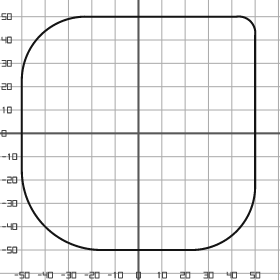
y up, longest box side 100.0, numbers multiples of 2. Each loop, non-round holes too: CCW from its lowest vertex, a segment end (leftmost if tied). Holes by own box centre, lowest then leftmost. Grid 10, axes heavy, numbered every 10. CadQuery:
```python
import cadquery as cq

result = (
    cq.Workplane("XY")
    .moveTo(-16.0, -50.0)
    .lineTo(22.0, -50.0)
    .threePointArc((42.0, -42.0), (50.0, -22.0))
    .lineTo(50.0, 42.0)
    .threePointArc((48.0, 48.0), (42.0, 50.0))
    .lineTo(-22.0, 50.0)
    .threePointArc((-42.0, 42.0), (-50.0, 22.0))
    .lineTo(-50.0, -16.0)
    .threePointArc((-40.0, -40.0), (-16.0, -50.0))
    .close()
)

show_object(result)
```